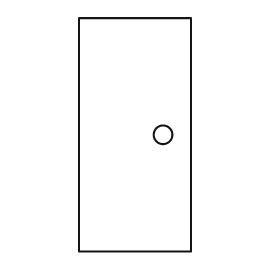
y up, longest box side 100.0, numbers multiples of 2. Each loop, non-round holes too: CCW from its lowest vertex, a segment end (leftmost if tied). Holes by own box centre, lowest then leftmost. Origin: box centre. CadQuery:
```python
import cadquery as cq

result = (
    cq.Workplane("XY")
    .moveTo(-24.0, -50.0)
    .lineTo(24.0, -50.0)
    .lineTo(24.0, 50.0)
    .lineTo(-24.0, 50.0)
    .close()
    .moveTo(12.0, 0.0)
    .circle(4.0)
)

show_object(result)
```